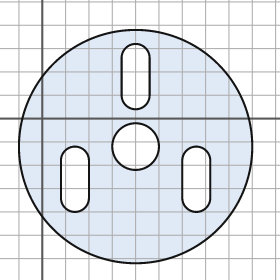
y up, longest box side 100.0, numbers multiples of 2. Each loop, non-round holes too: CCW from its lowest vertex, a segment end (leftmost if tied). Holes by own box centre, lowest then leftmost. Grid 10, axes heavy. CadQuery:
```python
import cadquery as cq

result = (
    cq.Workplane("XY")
    .moveTo(40.0, -12.0)
    .circle(50.0)
    .moveTo(8.0, -34.0)
    .threePointArc((14.0, -40.0), (20.0, -34.0))
    .lineTo(20.0, -18.0)
    .threePointArc((14.0, -12.0), (8.0, -18.0))
    .close()
    .moveTo(60.0, -34.0)
    .threePointArc((66.0, -40.0), (72.0, -34.0))
    .lineTo(72.0, -18.0)
    .threePointArc((66.0, -12.0), (60.0, -18.0))
    .close()
    .moveTo(40.0, -12.0)
    .circle(10.0)
    .moveTo(34.0, 10.0)
    .threePointArc((40.0, 4.0), (46.0, 10.0))
    .lineTo(46.0, 26.0)
    .threePointArc((40.0, 32.0), (34.0, 26.0))
    .close()
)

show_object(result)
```